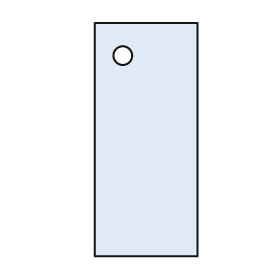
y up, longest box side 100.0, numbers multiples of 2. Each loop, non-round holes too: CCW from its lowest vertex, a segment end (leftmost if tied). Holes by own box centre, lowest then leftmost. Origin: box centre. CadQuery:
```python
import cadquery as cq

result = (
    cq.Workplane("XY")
    .moveTo(-22.0, -50.0)
    .lineTo(22.0, -50.0)
    .lineTo(22.0, 50.0)
    .lineTo(-22.0, 50.0)
    .close()
    .moveTo(-10.0, 36.0)
    .circle(4.0)
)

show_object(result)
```